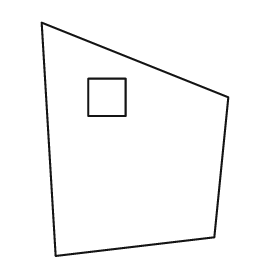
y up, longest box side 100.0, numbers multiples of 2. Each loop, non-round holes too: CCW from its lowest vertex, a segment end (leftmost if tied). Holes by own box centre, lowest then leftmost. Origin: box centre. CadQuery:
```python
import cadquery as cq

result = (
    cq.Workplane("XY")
    .moveTo(-34.0, -50.0)
    .lineTo(34.0, -42.0)
    .lineTo(40.0, 18.0)
    .lineTo(-40.0, 50.0)
    .close()
    .moveTo(-20.0, 10.0)
    .lineTo(-4.0, 10.0)
    .lineTo(-4.0, 26.0)
    .lineTo(-20.0, 26.0)
    .close()
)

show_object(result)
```